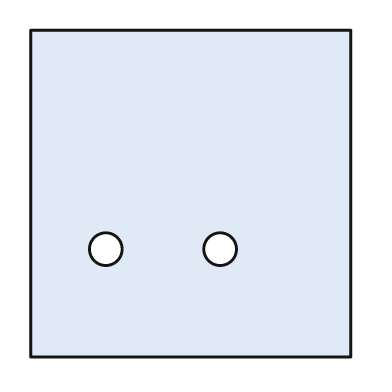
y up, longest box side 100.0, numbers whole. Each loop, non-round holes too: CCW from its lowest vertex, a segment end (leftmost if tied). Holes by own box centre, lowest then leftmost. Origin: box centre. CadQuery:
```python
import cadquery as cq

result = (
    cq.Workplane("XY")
    .moveTo(-49.0, -50.0)
    .lineTo(49.0, -50.0)
    .lineTo(49.0, 50.0)
    .lineTo(-49.0, 50.0)
    .close()
    .moveTo(-26.0, -17.0)
    .circle(5.0)
    .moveTo(9.0, -17.0)
    .circle(5.0)
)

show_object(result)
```